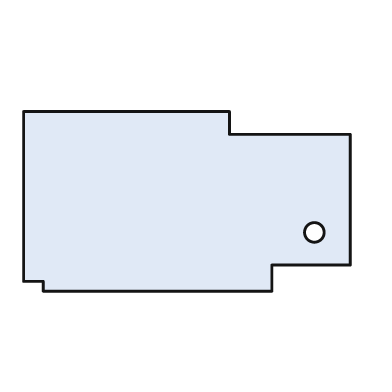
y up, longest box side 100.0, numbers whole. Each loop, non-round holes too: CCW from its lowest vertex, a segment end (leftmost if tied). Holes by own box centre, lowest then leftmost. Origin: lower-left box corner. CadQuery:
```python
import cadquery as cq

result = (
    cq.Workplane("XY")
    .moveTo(6.0, 0.0)
    .lineTo(76.0, 0.0)
    .lineTo(76.0, 8.0)
    .lineTo(100.0, 8.0)
    .lineTo(100.0, 48.0)
    .lineTo(63.0, 48.0)
    .lineTo(63.0, 55.0)
    .lineTo(0.0, 55.0)
    .lineTo(0.0, 3.0)
    .lineTo(6.0, 3.0)
    .close()
    .moveTo(89.0, 18.0)
    .circle(3.0)
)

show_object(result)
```